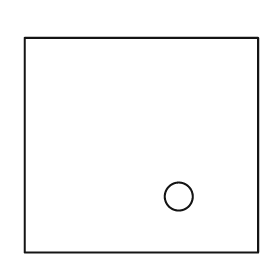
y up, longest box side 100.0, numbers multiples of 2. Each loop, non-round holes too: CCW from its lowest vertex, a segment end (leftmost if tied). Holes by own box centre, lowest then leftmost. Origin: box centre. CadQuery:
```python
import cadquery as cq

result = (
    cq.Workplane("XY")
    .moveTo(-50.0, -46.0)
    .lineTo(50.0, -46.0)
    .lineTo(50.0, 46.0)
    .lineTo(-50.0, 46.0)
    .close()
    .moveTo(16.0, -22.0)
    .circle(6.0)
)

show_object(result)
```